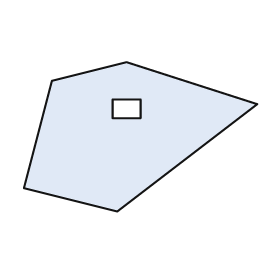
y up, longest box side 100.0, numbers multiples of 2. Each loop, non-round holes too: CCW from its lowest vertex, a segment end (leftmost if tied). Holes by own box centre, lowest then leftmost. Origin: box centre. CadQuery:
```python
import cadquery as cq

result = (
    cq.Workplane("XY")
    .moveTo(-10.0, -32.0)
    .lineTo(50.0, 14.0)
    .lineTo(-6.0, 32.0)
    .lineTo(-38.0, 24.0)
    .lineTo(-50.0, -22.0)
    .close()
    .moveTo(-12.0, 8.0)
    .lineTo(0.0, 8.0)
    .lineTo(0.0, 16.0)
    .lineTo(-12.0, 16.0)
    .close()
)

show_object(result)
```